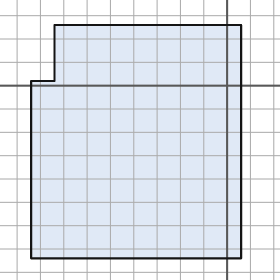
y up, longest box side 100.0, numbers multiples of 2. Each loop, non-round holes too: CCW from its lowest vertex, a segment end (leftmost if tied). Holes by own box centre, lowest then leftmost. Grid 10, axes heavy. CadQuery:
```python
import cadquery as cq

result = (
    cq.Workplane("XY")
    .moveTo(-84.0, -74.0)
    .lineTo(6.0, -74.0)
    .lineTo(6.0, 26.0)
    .lineTo(-74.0, 26.0)
    .lineTo(-74.0, 2.0)
    .lineTo(-84.0, 2.0)
    .close()
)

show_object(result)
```